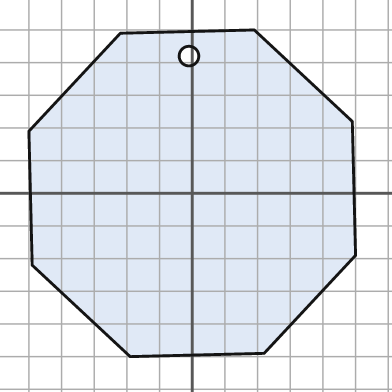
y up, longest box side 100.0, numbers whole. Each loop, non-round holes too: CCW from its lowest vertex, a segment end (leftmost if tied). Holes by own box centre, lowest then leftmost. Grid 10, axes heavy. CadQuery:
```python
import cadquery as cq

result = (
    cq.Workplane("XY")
    .moveTo(-19.0, -50.0)
    .lineTo(22.0, -49.0)
    .lineTo(50.0, -19.0)
    .lineTo(49.0, 22.0)
    .lineTo(19.0, 50.0)
    .lineTo(-22.0, 49.0)
    .lineTo(-50.0, 19.0)
    .lineTo(-49.0, -22.0)
    .close()
    .moveTo(-1.0, 42.0)
    .circle(3.0)
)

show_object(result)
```